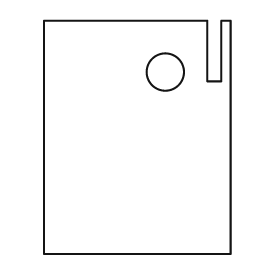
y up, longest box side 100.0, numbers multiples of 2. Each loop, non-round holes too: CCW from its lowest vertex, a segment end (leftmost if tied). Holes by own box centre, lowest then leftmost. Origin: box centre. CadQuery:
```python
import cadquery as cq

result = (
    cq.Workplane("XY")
    .moveTo(-40.0, -50.0)
    .lineTo(40.0, -50.0)
    .lineTo(40.0, 50.0)
    .lineTo(36.0, 50.0)
    .lineTo(36.0, 24.0)
    .lineTo(30.0, 24.0)
    .lineTo(30.0, 50.0)
    .lineTo(-40.0, 50.0)
    .close()
    .moveTo(12.0, 28.0)
    .circle(8.0)
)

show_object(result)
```